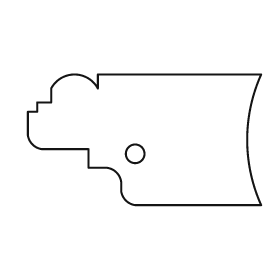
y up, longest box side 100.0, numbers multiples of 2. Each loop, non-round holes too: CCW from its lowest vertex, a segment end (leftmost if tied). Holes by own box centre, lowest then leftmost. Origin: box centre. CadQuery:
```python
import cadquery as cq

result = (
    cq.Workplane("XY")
    .moveTo(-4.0, -28.0)
    .lineTo(50.0, -28.0)
    .threePointArc((44.0, 0.0), (50.0, 28.0))
    .lineTo(-20.0, 28.0)
    .lineTo(-20.0, 22.0)
    .threePointArc((-30.0, 28.0), (-40.0, 22.0))
    .lineTo(-40.0, 16.0)
    .lineTo(-46.0, 16.0)
    .lineTo(-46.0, 12.0)
    .lineTo(-50.0, 12.0)
    .lineTo(-50.0, 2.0)
    .threePointArc((-48.0, -2.0), (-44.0, -4.0))
    .lineTo(-24.0, -4.0)
    .lineTo(-24.0, -12.0)
    .lineTo(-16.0, -12.0)
    .threePointArc((-12.0, -14.0), (-10.0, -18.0))
    .lineTo(-10.0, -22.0)
    .threePointArc((-8.0, -26.0), (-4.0, -28.0))
    .close()
    .moveTo(-4.0, -6.0)
    .circle(4.0)
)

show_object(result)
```